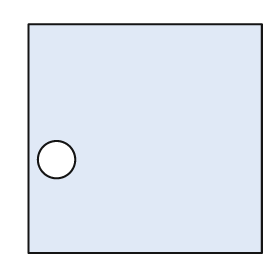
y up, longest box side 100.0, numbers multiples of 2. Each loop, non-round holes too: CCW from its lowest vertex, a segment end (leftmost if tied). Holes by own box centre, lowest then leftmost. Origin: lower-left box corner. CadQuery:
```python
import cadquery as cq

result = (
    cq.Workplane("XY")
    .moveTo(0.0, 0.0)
    .lineTo(100.0, 0.0)
    .lineTo(100.0, 98.0)
    .lineTo(0.0, 98.0)
    .close()
    .moveTo(12.0, 40.0)
    .circle(8.0)
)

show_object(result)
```